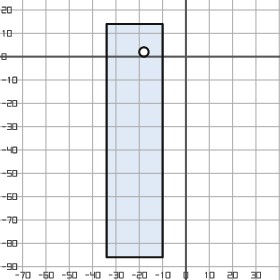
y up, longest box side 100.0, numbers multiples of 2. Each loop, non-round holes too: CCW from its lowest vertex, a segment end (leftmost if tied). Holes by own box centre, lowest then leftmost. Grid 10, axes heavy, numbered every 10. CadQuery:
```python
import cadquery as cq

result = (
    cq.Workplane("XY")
    .moveTo(-34.0, -86.0)
    .lineTo(-10.0, -86.0)
    .lineTo(-10.0, 14.0)
    .lineTo(-34.0, 14.0)
    .close()
    .moveTo(-18.0, 2.0)
    .circle(2.0)
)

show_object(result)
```